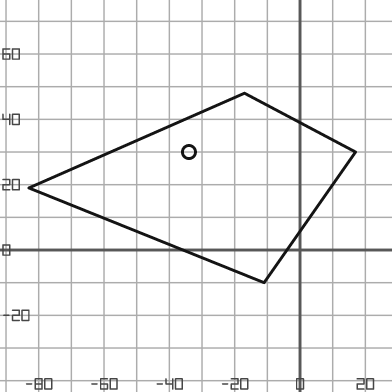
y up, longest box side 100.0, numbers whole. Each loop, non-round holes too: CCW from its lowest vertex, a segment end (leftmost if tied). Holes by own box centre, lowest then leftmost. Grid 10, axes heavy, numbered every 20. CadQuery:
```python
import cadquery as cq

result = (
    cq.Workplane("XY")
    .moveTo(-11.0, -10.0)
    .lineTo(17.0, 30.0)
    .lineTo(-17.0, 48.0)
    .lineTo(-83.0, 19.0)
    .close()
    .moveTo(-34.0, 30.0)
    .circle(2.0)
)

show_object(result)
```